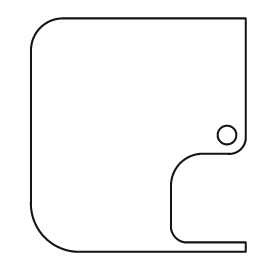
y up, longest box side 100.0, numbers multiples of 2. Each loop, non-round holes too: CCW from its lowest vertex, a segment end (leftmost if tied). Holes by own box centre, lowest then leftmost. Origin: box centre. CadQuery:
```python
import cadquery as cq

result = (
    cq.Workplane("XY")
    .moveTo(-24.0, -50.0)
    .lineTo(46.0, -50.0)
    .lineTo(46.0, -46.0)
    .lineTo(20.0, -46.0)
    .threePointArc((16.0, -44.0), (14.0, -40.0))
    .lineTo(14.0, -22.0)
    .threePointArc((18.0, -12.0), (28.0, -8.0))
    .lineTo(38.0, -8.0)
    .threePointArc((44.0, -6.0), (46.0, 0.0))
    .lineTo(46.0, 50.0)
    .lineTo(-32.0, 50.0)
    .threePointArc((-42.0, 46.0), (-46.0, 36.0))
    .lineTo(-46.0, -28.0)
    .threePointArc((-40.0, -44.0), (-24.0, -50.0))
    .close()
    .moveTo(38.0, 0.0)
    .circle(4.0)
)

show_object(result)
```